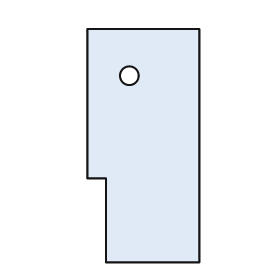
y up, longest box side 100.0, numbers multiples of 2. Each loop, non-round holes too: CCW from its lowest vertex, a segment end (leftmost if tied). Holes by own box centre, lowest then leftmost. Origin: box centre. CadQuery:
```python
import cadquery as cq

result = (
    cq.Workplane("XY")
    .moveTo(-16.0, -50.0)
    .lineTo(24.0, -50.0)
    .lineTo(24.0, 50.0)
    .lineTo(-24.0, 50.0)
    .lineTo(-24.0, -14.0)
    .lineTo(-16.0, -14.0)
    .close()
    .moveTo(-6.0, 30.0)
    .circle(4.0)
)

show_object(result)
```